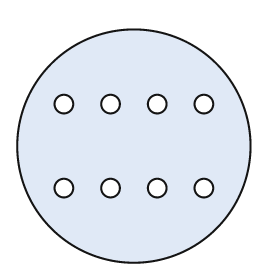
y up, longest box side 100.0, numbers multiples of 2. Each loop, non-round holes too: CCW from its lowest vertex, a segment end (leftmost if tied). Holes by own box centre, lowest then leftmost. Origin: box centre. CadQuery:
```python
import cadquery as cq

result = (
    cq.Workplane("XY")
    .moveTo(0.0, 0.0)
    .circle(50.0)
    .moveTo(-30.0, -18.0)
    .circle(4.0)
    .moveTo(-10.0, -18.0)
    .circle(4.0)
    .moveTo(10.0, -18.0)
    .circle(4.0)
    .moveTo(30.0, -18.0)
    .circle(4.0)
    .moveTo(-30.0, 18.0)
    .circle(4.0)
    .moveTo(-10.0, 18.0)
    .circle(4.0)
    .moveTo(10.0, 18.0)
    .circle(4.0)
    .moveTo(30.0, 18.0)
    .circle(4.0)
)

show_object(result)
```